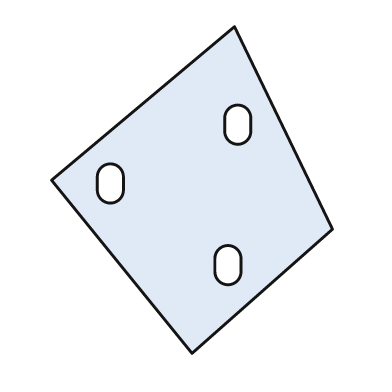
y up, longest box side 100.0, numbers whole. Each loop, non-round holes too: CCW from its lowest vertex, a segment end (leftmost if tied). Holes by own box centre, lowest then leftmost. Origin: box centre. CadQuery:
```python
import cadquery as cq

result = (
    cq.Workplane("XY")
    .moveTo(0.0, -50.0)
    .lineTo(43.0, -12.0)
    .lineTo(13.0, 50.0)
    .lineTo(-43.0, 3.0)
    .close()
    .moveTo(7.0, -25.0)
    .threePointArc((11.0, -29.0), (15.0, -25.0))
    .lineTo(15.0, -21.0)
    .threePointArc((11.0, -17.0), (7.0, -21.0))
    .close()
    .moveTo(-29.0, 0.0)
    .threePointArc((-25.0, -4.0), (-21.0, 0.0))
    .lineTo(-21.0, 4.0)
    .threePointArc((-25.0, 8.0), (-29.0, 4.0))
    .close()
    .moveTo(10.0, 18.0)
    .threePointArc((14.0, 14.0), (18.0, 18.0))
    .lineTo(18.0, 22.0)
    .threePointArc((14.0, 26.0), (10.0, 22.0))
    .close()
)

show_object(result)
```